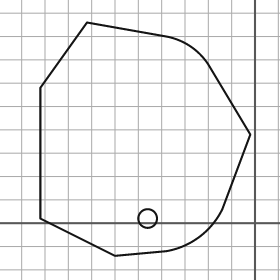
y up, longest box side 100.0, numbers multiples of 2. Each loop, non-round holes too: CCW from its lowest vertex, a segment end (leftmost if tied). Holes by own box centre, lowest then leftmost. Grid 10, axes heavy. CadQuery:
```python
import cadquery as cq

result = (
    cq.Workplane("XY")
    .moveTo(-60.0, -14.0)
    .lineTo(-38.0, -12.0)
    .threePointArc((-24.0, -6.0), (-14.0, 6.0))
    .lineTo(-2.0, 38.0)
    .lineTo(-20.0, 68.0)
    .threePointArc((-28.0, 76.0), (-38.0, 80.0))
    .lineTo(-72.0, 86.0)
    .lineTo(-92.0, 58.0)
    .lineTo(-92.0, 2.0)
    .close()
    .moveTo(-46.0, 2.0)
    .circle(4.0)
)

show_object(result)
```